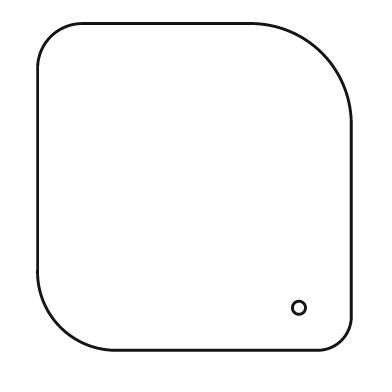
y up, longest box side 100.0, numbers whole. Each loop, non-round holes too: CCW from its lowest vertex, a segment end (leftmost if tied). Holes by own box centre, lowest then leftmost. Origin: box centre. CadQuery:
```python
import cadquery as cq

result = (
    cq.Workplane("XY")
    .moveTo(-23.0, -50.0)
    .lineTo(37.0, -50.0)
    .threePointArc((45.0, -47.0), (48.0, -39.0))
    .lineTo(48.0, 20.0)
    .threePointArc((39.0, 41.0), (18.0, 50.0))
    .lineTo(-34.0, 50.0)
    .threePointArc((-44.0, 46.0), (-48.0, 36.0))
    .lineTo(-48.0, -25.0)
    .threePointArc((-41.0, -43.0), (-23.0, -50.0))
    .close()
    .moveTo(32.0, -37.0)
    .circle(2.0)
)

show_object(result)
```